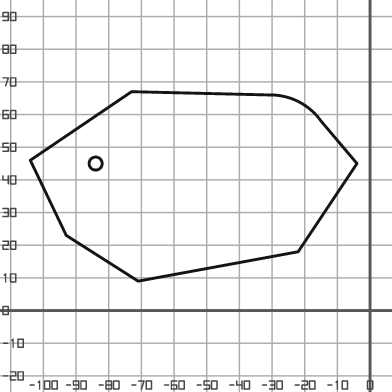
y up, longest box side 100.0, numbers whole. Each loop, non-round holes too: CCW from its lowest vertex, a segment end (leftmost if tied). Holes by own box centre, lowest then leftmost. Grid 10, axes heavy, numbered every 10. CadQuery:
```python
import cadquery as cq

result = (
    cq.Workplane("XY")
    .moveTo(-71.0, 9.0)
    .lineTo(-22.0, 18.0)
    .lineTo(-4.0, 45.0)
    .lineTo(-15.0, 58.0)
    .threePointArc((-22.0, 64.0), (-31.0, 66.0))
    .lineTo(-73.0, 67.0)
    .lineTo(-104.0, 46.0)
    .lineTo(-93.0, 23.0)
    .close()
    .moveTo(-84.0, 45.0)
    .circle(2.0)
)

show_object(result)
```